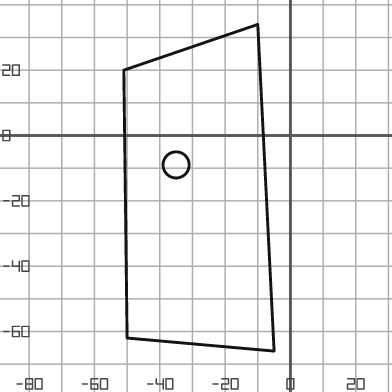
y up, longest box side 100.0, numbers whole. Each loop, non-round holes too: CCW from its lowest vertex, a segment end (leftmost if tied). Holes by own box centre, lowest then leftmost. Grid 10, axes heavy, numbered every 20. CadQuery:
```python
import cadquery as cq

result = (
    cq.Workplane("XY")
    .moveTo(-5.0, -66.0)
    .lineTo(-10.0, 34.0)
    .lineTo(-51.0, 20.0)
    .lineTo(-50.0, -62.0)
    .close()
    .moveTo(-35.0, -9.0)
    .circle(4.0)
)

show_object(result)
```